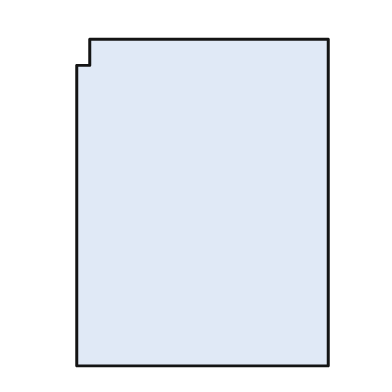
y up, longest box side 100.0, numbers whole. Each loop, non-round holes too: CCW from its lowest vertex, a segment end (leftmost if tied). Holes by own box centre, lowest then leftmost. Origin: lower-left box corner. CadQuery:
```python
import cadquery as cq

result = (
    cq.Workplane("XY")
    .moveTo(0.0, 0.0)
    .lineTo(77.0, 0.0)
    .lineTo(77.0, 100.0)
    .lineTo(4.0, 100.0)
    .lineTo(4.0, 92.0)
    .lineTo(0.0, 92.0)
    .close()
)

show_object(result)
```